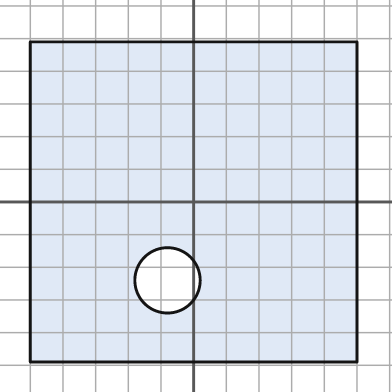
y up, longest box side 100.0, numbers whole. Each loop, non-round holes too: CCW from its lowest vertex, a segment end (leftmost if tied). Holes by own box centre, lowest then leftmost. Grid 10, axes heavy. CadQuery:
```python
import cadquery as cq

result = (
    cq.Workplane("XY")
    .moveTo(-50.0, -49.0)
    .lineTo(50.0, -49.0)
    .lineTo(50.0, 49.0)
    .lineTo(-50.0, 49.0)
    .close()
    .moveTo(-8.0, -24.0)
    .circle(10.0)
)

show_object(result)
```